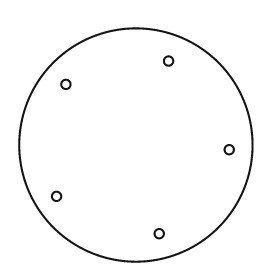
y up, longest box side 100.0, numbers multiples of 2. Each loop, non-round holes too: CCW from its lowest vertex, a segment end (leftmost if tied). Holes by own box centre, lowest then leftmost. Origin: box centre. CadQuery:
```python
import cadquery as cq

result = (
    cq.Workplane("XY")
    .moveTo(0.0, 0.0)
    .circle(50.0)
    .moveTo(10.0, -38.0)
    .circle(2.0)
    .moveTo(-34.0, -22.0)
    .circle(2.0)
    .moveTo(40.0, -2.0)
    .circle(2.0)
    .moveTo(-30.0, 26.0)
    .circle(2.0)
    .moveTo(14.0, 36.0)
    .circle(2.0)
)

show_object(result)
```